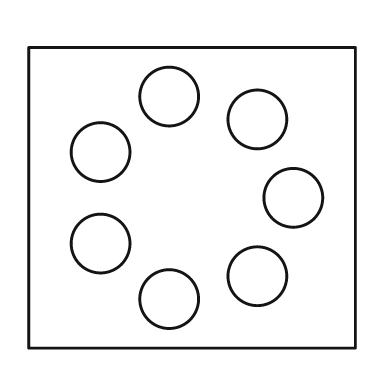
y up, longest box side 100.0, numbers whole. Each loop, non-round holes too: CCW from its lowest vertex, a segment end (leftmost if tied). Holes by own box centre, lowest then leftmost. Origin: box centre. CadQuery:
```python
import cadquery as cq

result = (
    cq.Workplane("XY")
    .moveTo(-50.0, -46.0)
    .lineTo(50.0, -46.0)
    .lineTo(50.0, 46.0)
    .lineTo(-50.0, 46.0)
    .close()
    .moveTo(-7.0, -31.0)
    .circle(9.0)
    .moveTo(20.0, -24.0)
    .circle(9.0)
    .moveTo(-28.0, -14.0)
    .circle(9.0)
    .moveTo(31.0, 0.0)
    .circle(9.0)
    .moveTo(-28.0, 14.0)
    .circle(9.0)
    .moveTo(20.0, 24.0)
    .circle(9.0)
    .moveTo(-7.0, 31.0)
    .circle(9.0)
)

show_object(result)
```